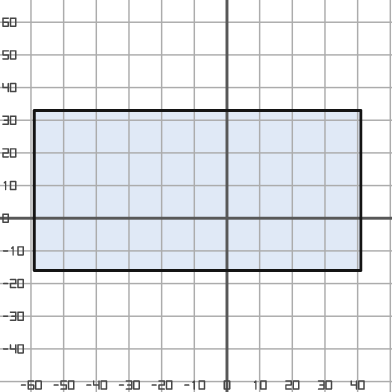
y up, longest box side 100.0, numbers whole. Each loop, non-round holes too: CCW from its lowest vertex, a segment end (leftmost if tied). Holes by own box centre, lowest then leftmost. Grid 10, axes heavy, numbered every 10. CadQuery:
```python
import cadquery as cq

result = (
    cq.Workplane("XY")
    .moveTo(-59.0, -16.0)
    .lineTo(41.0, -16.0)
    .lineTo(41.0, 33.0)
    .lineTo(-59.0, 33.0)
    .close()
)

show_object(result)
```